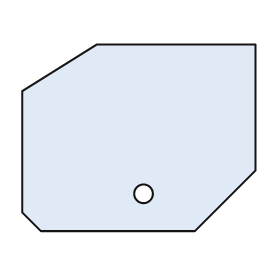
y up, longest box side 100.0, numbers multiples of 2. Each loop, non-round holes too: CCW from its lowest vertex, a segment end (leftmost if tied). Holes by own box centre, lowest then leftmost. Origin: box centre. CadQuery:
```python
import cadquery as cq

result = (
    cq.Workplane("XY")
    .moveTo(-42.0, -40.0)
    .lineTo(24.0, -40.0)
    .lineTo(50.0, -14.0)
    .lineTo(50.0, 40.0)
    .lineTo(-18.0, 40.0)
    .lineTo(-50.0, 20.0)
    .lineTo(-50.0, -32.0)
    .close()
    .moveTo(2.0, -24.0)
    .circle(4.0)
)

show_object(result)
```